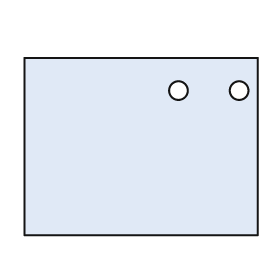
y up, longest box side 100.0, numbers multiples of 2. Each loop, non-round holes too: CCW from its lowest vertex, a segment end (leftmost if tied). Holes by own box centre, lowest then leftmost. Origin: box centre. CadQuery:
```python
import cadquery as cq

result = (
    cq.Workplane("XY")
    .moveTo(-50.0, -38.0)
    .lineTo(50.0, -38.0)
    .lineTo(50.0, 38.0)
    .lineTo(-50.0, 38.0)
    .close()
    .moveTo(16.0, 24.0)
    .circle(4.0)
    .moveTo(42.0, 24.0)
    .circle(4.0)
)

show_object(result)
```